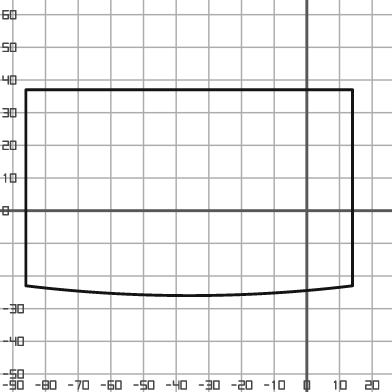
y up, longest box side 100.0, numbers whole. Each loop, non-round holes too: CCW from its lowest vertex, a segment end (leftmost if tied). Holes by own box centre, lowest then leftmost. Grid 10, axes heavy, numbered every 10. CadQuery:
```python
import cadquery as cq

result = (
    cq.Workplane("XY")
    .moveTo(-86.0, -23.0)
    .threePointArc((-36.0, -26.0), (14.0, -23.0))
    .lineTo(14.0, 37.0)
    .lineTo(-86.0, 37.0)
    .close()
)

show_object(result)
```